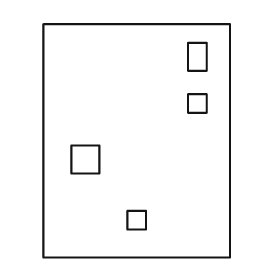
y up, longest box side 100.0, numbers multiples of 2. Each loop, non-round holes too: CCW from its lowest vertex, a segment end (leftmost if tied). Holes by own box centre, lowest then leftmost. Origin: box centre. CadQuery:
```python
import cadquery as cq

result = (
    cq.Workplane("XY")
    .moveTo(-40.0, -50.0)
    .lineTo(40.0, -50.0)
    .lineTo(40.0, 50.0)
    .lineTo(-40.0, 50.0)
    .close()
    .moveTo(-4.0, -38.0)
    .lineTo(4.0, -38.0)
    .lineTo(4.0, -30.0)
    .lineTo(-4.0, -30.0)
    .close()
    .moveTo(-28.0, -14.0)
    .lineTo(-16.0, -14.0)
    .lineTo(-16.0, -2.0)
    .lineTo(-28.0, -2.0)
    .close()
    .moveTo(22.0, 12.0)
    .lineTo(30.0, 12.0)
    .lineTo(30.0, 20.0)
    .lineTo(22.0, 20.0)
    .close()
    .moveTo(22.0, 30.0)
    .lineTo(30.0, 30.0)
    .lineTo(30.0, 42.0)
    .lineTo(22.0, 42.0)
    .close()
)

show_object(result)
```